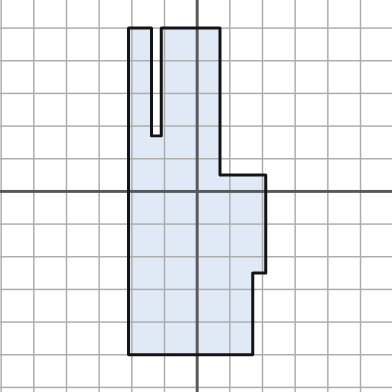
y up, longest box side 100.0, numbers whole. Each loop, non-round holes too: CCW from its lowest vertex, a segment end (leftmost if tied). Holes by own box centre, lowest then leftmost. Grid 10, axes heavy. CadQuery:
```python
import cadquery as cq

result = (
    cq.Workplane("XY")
    .moveTo(-21.0, -50.0)
    .lineTo(17.0, -50.0)
    .lineTo(17.0, -25.0)
    .lineTo(21.0, -25.0)
    .lineTo(21.0, 5.0)
    .lineTo(7.0, 5.0)
    .lineTo(7.0, 50.0)
    .lineTo(-11.0, 50.0)
    .lineTo(-11.0, 17.0)
    .lineTo(-14.0, 17.0)
    .lineTo(-14.0, 50.0)
    .lineTo(-21.0, 50.0)
    .close()
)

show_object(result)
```